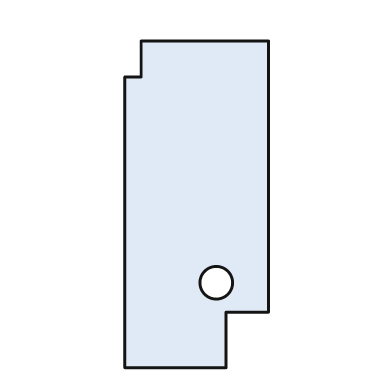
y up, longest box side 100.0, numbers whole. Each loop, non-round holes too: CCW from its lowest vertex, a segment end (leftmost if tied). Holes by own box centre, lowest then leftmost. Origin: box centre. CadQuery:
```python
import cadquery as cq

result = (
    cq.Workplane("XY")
    .moveTo(-22.0, -50.0)
    .lineTo(9.0, -50.0)
    .lineTo(9.0, -33.0)
    .lineTo(22.0, -33.0)
    .lineTo(22.0, 50.0)
    .lineTo(-17.0, 50.0)
    .lineTo(-17.0, 39.0)
    .lineTo(-22.0, 39.0)
    .close()
    .moveTo(6.0, -24.0)
    .circle(5.0)
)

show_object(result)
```